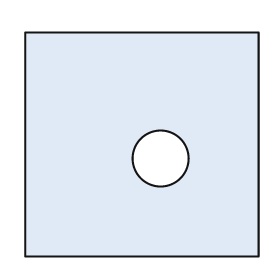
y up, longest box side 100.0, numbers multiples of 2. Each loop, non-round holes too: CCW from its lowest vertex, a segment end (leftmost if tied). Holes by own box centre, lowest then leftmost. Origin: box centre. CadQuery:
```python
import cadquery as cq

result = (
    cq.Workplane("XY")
    .moveTo(-50.0, -48.0)
    .lineTo(50.0, -48.0)
    .lineTo(50.0, 48.0)
    .lineTo(-50.0, 48.0)
    .close()
    .moveTo(8.0, -6.0)
    .circle(12.0)
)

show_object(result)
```